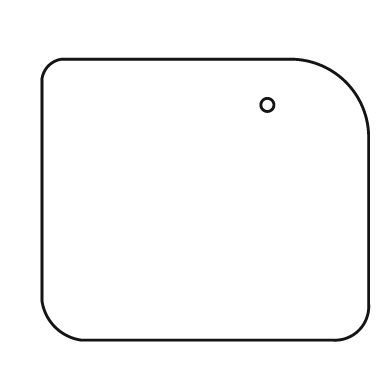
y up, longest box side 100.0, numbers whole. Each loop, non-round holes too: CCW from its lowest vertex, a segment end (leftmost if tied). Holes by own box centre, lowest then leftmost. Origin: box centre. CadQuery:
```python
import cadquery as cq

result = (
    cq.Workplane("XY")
    .moveTo(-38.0, -43.0)
    .lineTo(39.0, -43.0)
    .threePointArc((47.0, -40.0), (50.0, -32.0))
    .lineTo(50.0, 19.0)
    .threePointArc((43.0, 36.0), (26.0, 43.0))
    .lineTo(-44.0, 43.0)
    .threePointArc((-48.0, 41.0), (-50.0, 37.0))
    .lineTo(-50.0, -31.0)
    .threePointArc((-46.0, -39.0), (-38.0, -43.0))
    .close()
    .moveTo(19.0, 29.0)
    .circle(2.0)
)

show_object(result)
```